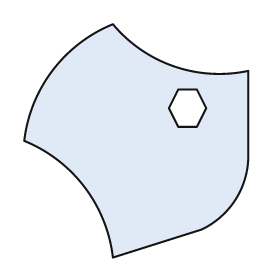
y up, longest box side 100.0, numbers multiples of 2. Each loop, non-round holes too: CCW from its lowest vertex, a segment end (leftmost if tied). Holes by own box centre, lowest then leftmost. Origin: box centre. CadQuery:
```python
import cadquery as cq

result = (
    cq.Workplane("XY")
    .moveTo(-10.0, -50.0)
    .lineTo(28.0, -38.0)
    .threePointArc((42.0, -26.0), (48.0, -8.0))
    .lineTo(48.0, 30.0)
    .threePointArc((16.0, 32.0), (-10.0, 50.0))
    .threePointArc((-36.0, 30.0), (-48.0, 0.0))
    .threePointArc((-22.0, -20.0), (-10.0, -50.0))
    .close()
    .moveTo(18.0, 6.0)
    .lineTo(26.0, 6.0)
    .lineTo(30.0, 14.0)
    .lineTo(26.0, 22.0)
    .lineTo(18.0, 22.0)
    .lineTo(14.0, 14.0)
    .close()
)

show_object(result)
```